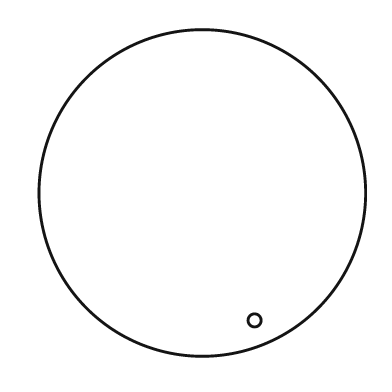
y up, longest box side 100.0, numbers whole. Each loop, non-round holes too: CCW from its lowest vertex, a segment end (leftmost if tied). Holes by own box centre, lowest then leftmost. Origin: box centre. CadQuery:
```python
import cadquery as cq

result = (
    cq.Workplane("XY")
    .moveTo(0.0, 0.0)
    .circle(50.0)
    .moveTo(16.0, -39.0)
    .circle(2.0)
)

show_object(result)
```